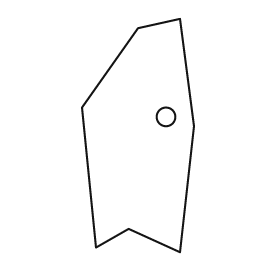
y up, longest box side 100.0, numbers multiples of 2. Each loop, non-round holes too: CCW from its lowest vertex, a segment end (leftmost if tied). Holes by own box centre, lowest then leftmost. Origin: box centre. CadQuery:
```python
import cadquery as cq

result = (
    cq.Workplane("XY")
    .moveTo(18.0, -50.0)
    .lineTo(24.0, 4.0)
    .lineTo(18.0, 50.0)
    .lineTo(0.0, 46.0)
    .lineTo(-24.0, 12.0)
    .lineTo(-18.0, -48.0)
    .lineTo(-4.0, -40.0)
    .close()
    .moveTo(12.0, 8.0)
    .circle(4.0)
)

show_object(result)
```